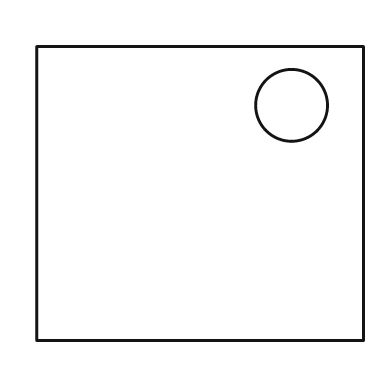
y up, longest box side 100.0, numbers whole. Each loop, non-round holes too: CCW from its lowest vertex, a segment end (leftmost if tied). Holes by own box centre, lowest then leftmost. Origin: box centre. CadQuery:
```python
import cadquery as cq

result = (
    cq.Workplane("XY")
    .moveTo(-50.0, -45.0)
    .lineTo(50.0, -45.0)
    .lineTo(50.0, 45.0)
    .lineTo(-50.0, 45.0)
    .close()
    .moveTo(28.0, 27.0)
    .circle(11.0)
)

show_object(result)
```